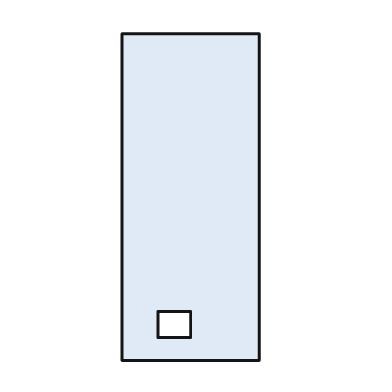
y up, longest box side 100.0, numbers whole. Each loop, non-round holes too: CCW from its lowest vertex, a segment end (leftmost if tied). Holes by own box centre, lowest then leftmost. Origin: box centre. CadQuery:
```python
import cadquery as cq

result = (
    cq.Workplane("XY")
    .moveTo(-21.0, -50.0)
    .lineTo(21.0, -50.0)
    .lineTo(21.0, 50.0)
    .lineTo(-21.0, 50.0)
    .close()
    .moveTo(-10.0, -43.0)
    .lineTo(0.0, -43.0)
    .lineTo(0.0, -35.0)
    .lineTo(-10.0, -35.0)
    .close()
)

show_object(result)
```